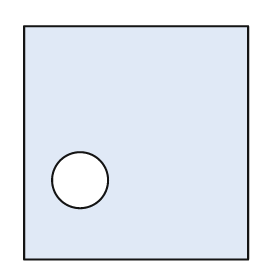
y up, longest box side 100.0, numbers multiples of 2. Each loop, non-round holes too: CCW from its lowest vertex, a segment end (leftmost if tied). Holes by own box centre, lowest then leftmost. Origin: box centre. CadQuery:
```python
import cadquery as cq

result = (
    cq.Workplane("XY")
    .moveTo(-48.0, -50.0)
    .lineTo(48.0, -50.0)
    .lineTo(48.0, 50.0)
    .lineTo(-48.0, 50.0)
    .close()
    .moveTo(-24.0, -16.0)
    .circle(12.0)
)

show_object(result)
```